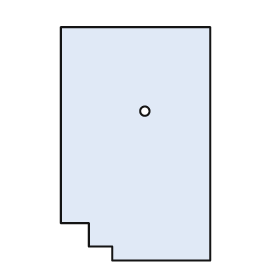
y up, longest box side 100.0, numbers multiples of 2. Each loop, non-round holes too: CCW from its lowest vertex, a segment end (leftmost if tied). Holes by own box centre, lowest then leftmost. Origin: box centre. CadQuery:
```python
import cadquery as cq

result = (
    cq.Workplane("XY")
    .moveTo(-10.0, -50.0)
    .lineTo(32.0, -50.0)
    .lineTo(32.0, 50.0)
    .lineTo(-32.0, 50.0)
    .lineTo(-32.0, -34.0)
    .lineTo(-20.0, -34.0)
    .lineTo(-20.0, -44.0)
    .lineTo(-10.0, -44.0)
    .close()
    .moveTo(4.0, 14.0)
    .circle(2.0)
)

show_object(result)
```